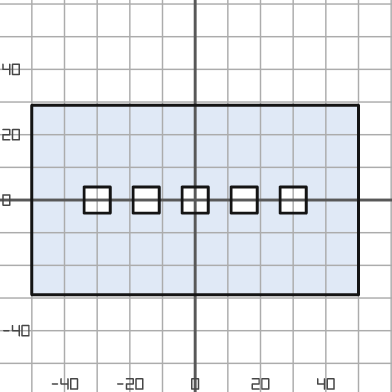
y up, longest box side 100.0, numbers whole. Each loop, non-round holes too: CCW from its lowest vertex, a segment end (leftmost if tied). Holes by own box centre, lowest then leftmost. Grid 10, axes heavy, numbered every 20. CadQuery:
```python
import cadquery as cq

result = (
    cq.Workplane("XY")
    .moveTo(-50.0, -29.0)
    .lineTo(50.0, -29.0)
    .lineTo(50.0, 29.0)
    .lineTo(-50.0, 29.0)
    .close()
    .moveTo(-34.0, -4.0)
    .lineTo(-26.0, -4.0)
    .lineTo(-26.0, 4.0)
    .lineTo(-34.0, 4.0)
    .close()
    .moveTo(-19.0, -4.0)
    .lineTo(-11.0, -4.0)
    .lineTo(-11.0, 4.0)
    .lineTo(-19.0, 4.0)
    .close()
    .moveTo(-4.0, -4.0)
    .lineTo(4.0, -4.0)
    .lineTo(4.0, 4.0)
    .lineTo(-4.0, 4.0)
    .close()
    .moveTo(11.0, -4.0)
    .lineTo(19.0, -4.0)
    .lineTo(19.0, 4.0)
    .lineTo(11.0, 4.0)
    .close()
    .moveTo(26.0, -4.0)
    .lineTo(34.0, -4.0)
    .lineTo(34.0, 4.0)
    .lineTo(26.0, 4.0)
    .close()
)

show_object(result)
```